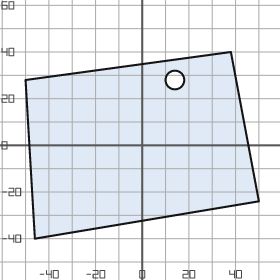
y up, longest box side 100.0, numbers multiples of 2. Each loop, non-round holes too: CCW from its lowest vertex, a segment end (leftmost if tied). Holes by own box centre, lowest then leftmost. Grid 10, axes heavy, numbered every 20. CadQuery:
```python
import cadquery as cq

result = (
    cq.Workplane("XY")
    .moveTo(-46.0, -40.0)
    .lineTo(50.0, -24.0)
    .lineTo(38.0, 40.0)
    .lineTo(-50.0, 28.0)
    .close()
    .moveTo(14.0, 28.0)
    .circle(4.0)
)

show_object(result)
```